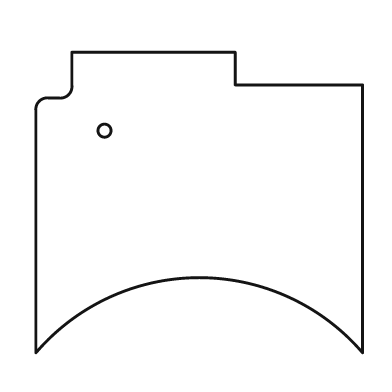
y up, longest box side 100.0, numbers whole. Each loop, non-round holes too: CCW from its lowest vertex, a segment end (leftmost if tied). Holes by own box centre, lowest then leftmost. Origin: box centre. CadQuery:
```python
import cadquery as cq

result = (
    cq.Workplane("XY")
    .moveTo(-50.0, -46.0)
    .threePointArc((0.0, -23.0), (50.0, -46.0))
    .lineTo(50.0, 36.0)
    .lineTo(11.0, 36.0)
    .lineTo(11.0, 46.0)
    .lineTo(-39.0, 46.0)
    .lineTo(-39.0, 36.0)
    .threePointArc((-40.0, 33.0), (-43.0, 32.0))
    .lineTo(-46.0, 32.0)
    .threePointArc((-49.0, 31.0), (-50.0, 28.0))
    .close()
    .moveTo(-29.0, 22.0)
    .circle(2.0)
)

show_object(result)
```